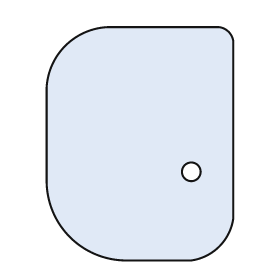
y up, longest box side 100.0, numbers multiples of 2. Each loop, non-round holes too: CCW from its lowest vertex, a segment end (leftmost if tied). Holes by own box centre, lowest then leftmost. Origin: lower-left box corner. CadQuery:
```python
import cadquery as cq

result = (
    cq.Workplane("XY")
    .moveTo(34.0, 0.0)
    .lineTo(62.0, 0.0)
    .threePointArc((74.0, 6.0), (80.0, 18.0))
    .lineTo(80.0, 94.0)
    .threePointArc((78.0, 98.0), (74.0, 100.0))
    .lineTo(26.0, 100.0)
    .threePointArc((8.0, 92.0), (0.0, 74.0))
    .lineTo(0.0, 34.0)
    .threePointArc((10.0, 10.0), (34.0, 0.0))
    .close()
    .moveTo(62.0, 38.0)
    .circle(4.0)
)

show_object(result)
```